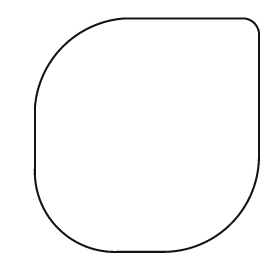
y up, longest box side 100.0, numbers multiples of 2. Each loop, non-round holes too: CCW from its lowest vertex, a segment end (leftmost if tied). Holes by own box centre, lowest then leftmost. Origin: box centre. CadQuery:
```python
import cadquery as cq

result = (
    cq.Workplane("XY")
    .moveTo(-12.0, -50.0)
    .lineTo(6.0, -50.0)
    .threePointArc((36.0, -38.0), (48.0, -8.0))
    .lineTo(48.0, 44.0)
    .threePointArc((46.0, 48.0), (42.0, 50.0))
    .lineTo(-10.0, 50.0)
    .threePointArc((-36.0, 38.0), (-48.0, 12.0))
    .lineTo(-48.0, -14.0)
    .threePointArc((-38.0, -40.0), (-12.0, -50.0))
    .close()
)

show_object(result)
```